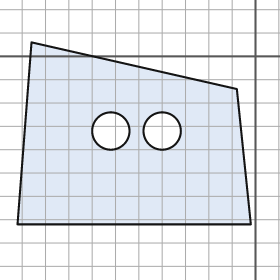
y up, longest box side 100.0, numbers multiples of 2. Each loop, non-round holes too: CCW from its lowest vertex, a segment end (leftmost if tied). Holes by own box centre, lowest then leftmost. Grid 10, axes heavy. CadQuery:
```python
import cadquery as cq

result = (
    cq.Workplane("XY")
    .moveTo(-102.0, -72.0)
    .lineTo(-2.0, -72.0)
    .lineTo(-8.0, -14.0)
    .lineTo(-96.0, 6.0)
    .close()
    .moveTo(-62.0, -32.0)
    .circle(8.0)
    .moveTo(-40.0, -32.0)
    .circle(8.0)
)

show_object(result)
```